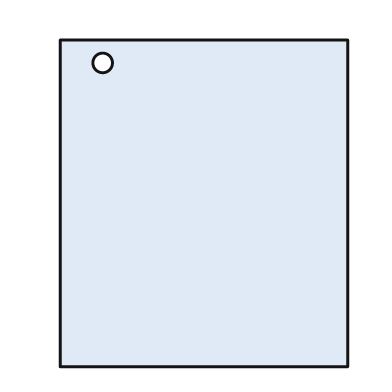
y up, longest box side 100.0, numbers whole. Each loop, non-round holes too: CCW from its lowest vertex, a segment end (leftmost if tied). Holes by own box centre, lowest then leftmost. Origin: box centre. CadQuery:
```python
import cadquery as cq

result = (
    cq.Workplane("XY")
    .moveTo(-44.0, -50.0)
    .lineTo(44.0, -50.0)
    .lineTo(44.0, 50.0)
    .lineTo(-44.0, 50.0)
    .close()
    .moveTo(-31.0, 43.0)
    .circle(3.0)
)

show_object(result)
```